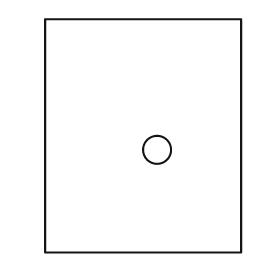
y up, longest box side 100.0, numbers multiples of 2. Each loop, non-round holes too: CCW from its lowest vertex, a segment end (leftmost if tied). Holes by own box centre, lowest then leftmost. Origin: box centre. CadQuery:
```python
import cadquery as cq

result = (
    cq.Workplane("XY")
    .moveTo(-42.0, -50.0)
    .lineTo(42.0, -50.0)
    .lineTo(42.0, 50.0)
    .lineTo(-42.0, 50.0)
    .close()
    .moveTo(6.0, -6.0)
    .circle(6.0)
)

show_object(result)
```